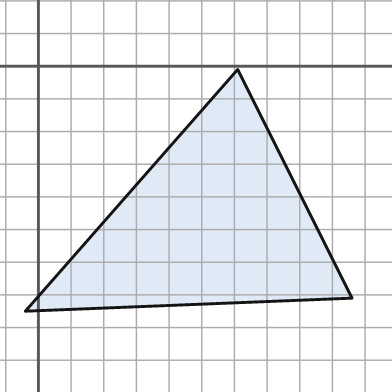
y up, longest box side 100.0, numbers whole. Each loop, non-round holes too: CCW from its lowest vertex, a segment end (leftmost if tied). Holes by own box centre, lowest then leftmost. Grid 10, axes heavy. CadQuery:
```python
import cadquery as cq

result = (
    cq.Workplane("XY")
    .moveTo(-4.0, -75.0)
    .lineTo(96.0, -71.0)
    .lineTo(61.0, -1.0)
    .close()
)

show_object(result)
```